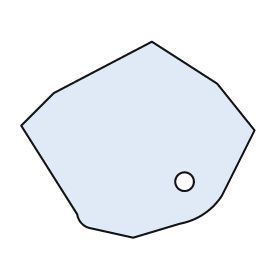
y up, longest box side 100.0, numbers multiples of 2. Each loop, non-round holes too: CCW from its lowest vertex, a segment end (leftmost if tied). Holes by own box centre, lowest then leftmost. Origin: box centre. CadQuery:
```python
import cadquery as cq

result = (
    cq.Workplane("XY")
    .moveTo(-2.0, -42.0)
    .lineTo(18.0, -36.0)
    .threePointArc((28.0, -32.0), (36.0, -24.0))
    .lineTo(50.0, 4.0)
    .lineTo(34.0, 24.0)
    .lineTo(6.0, 42.0)
    .lineTo(-36.0, 20.0)
    .lineTo(-50.0, 6.0)
    .lineTo(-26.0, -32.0)
    .threePointArc((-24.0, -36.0), (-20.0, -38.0))
    .close()
    .moveTo(20.0, -18.0)
    .circle(4.0)
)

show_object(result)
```